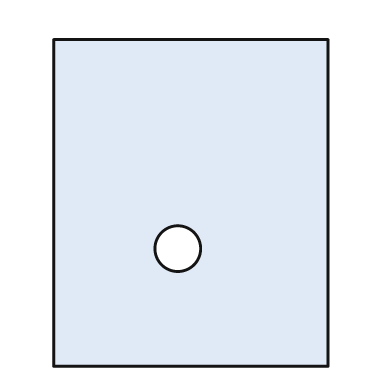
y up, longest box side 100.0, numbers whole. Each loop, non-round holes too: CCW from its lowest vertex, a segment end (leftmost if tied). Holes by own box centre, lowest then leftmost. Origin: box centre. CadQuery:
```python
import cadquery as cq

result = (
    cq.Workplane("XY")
    .moveTo(-42.0, -50.0)
    .lineTo(42.0, -50.0)
    .lineTo(42.0, 50.0)
    .lineTo(-42.0, 50.0)
    .close()
    .moveTo(-4.0, -14.0)
    .circle(7.0)
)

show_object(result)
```